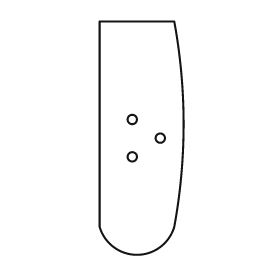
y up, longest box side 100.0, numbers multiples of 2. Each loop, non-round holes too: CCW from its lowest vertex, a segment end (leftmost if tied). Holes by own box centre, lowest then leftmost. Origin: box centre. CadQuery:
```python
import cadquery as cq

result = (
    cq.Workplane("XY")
    .moveTo(-18.0, -38.0)
    .threePointArc((-2.0, -50.0), (14.0, -38.0))
    .threePointArc((18.0, 6.0), (14.0, 50.0))
    .lineTo(-18.0, 50.0)
    .close()
    .moveTo(-4.0, -8.0)
    .circle(2.0)
    .moveTo(8.0, 0.0)
    .circle(2.0)
    .moveTo(-4.0, 8.0)
    .circle(2.0)
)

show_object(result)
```